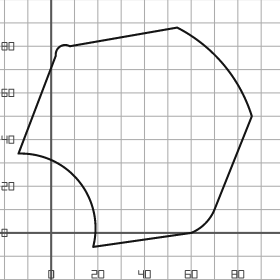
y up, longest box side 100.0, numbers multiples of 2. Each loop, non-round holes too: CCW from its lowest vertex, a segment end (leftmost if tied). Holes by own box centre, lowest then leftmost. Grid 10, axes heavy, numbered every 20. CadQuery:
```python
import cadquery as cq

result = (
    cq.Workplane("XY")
    .moveTo(18.0, -6.0)
    .lineTo(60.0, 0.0)
    .threePointArc((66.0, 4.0), (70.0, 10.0))
    .lineTo(86.0, 50.0)
    .threePointArc((74.0, 72.0), (54.0, 88.0))
    .lineTo(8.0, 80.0)
    .threePointArc((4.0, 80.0), (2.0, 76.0))
    .lineTo(-14.0, 34.0)
    .threePointArc((12.0, 22.0), (18.0, -6.0))
    .close()
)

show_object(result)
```